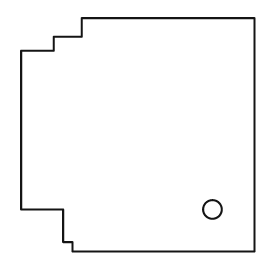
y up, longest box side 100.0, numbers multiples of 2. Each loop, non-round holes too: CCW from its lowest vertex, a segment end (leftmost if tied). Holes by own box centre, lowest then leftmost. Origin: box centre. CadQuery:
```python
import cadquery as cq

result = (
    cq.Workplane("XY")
    .moveTo(-28.0, -50.0)
    .lineTo(50.0, -50.0)
    .lineTo(50.0, 50.0)
    .lineTo(-24.0, 50.0)
    .lineTo(-24.0, 42.0)
    .lineTo(-36.0, 42.0)
    .lineTo(-36.0, 36.0)
    .lineTo(-50.0, 36.0)
    .lineTo(-50.0, -32.0)
    .lineTo(-32.0, -32.0)
    .lineTo(-32.0, -46.0)
    .lineTo(-28.0, -46.0)
    .close()
    .moveTo(32.0, -32.0)
    .circle(4.0)
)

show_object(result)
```